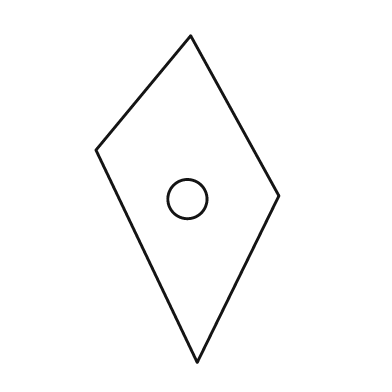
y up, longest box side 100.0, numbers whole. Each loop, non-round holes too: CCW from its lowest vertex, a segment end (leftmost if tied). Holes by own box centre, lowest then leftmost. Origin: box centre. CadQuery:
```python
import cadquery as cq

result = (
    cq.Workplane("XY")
    .moveTo(3.0, -50.0)
    .lineTo(28.0, 1.0)
    .lineTo(1.0, 50.0)
    .lineTo(-28.0, 15.0)
    .close()
    .moveTo(0.0, 0.0)
    .circle(6.0)
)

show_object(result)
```